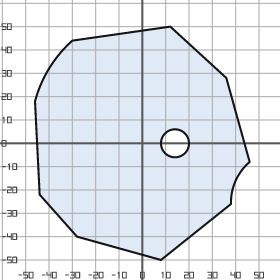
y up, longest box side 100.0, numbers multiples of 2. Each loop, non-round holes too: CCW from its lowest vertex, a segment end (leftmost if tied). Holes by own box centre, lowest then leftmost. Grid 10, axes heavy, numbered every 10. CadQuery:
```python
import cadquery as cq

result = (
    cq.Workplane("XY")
    .moveTo(8.0, -50.0)
    .lineTo(38.0, -26.0)
    .threePointArc((40.0, -16.0), (46.0, -8.0))
    .lineTo(36.0, 28.0)
    .lineTo(12.0, 50.0)
    .lineTo(-30.0, 44.0)
    .threePointArc((-40.0, 32.0), (-46.0, 18.0))
    .lineTo(-44.0, -22.0)
    .lineTo(-28.0, -40.0)
    .close()
    .moveTo(14.0, 0.0)
    .circle(6.0)
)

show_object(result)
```